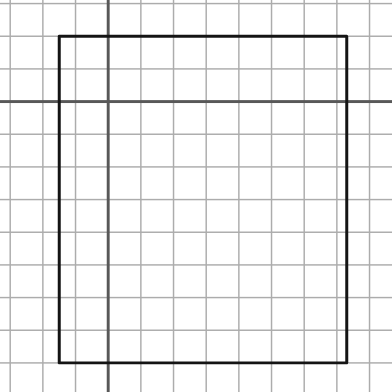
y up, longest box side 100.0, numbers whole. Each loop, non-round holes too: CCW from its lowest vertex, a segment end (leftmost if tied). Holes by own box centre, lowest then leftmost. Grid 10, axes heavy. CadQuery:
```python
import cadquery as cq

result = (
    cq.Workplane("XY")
    .moveTo(-15.0, -80.0)
    .lineTo(73.0, -80.0)
    .lineTo(73.0, 20.0)
    .lineTo(-15.0, 20.0)
    .close()
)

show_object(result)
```